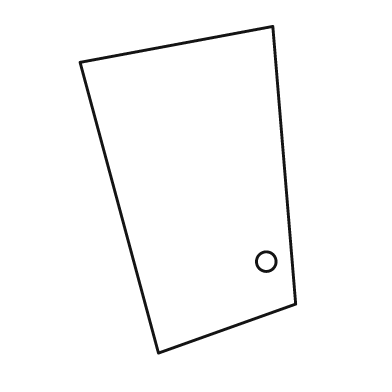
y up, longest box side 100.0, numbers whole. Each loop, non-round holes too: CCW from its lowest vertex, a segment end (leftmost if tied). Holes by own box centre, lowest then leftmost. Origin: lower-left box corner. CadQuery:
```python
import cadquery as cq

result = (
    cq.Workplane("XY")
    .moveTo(24.0, 0.0)
    .lineTo(66.0, 15.0)
    .lineTo(59.0, 100.0)
    .lineTo(0.0, 89.0)
    .close()
    .moveTo(57.0, 28.0)
    .circle(3.0)
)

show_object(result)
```